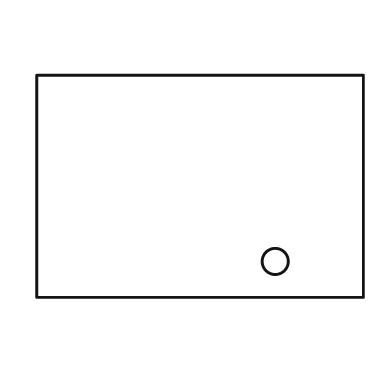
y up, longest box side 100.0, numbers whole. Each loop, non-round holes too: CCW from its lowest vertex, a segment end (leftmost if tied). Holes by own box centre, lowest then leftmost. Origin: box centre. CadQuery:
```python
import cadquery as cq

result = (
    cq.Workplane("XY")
    .moveTo(-50.0, -34.0)
    .lineTo(50.0, -34.0)
    .lineTo(50.0, 34.0)
    .lineTo(-50.0, 34.0)
    .close()
    .moveTo(23.0, -23.0)
    .circle(4.0)
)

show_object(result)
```